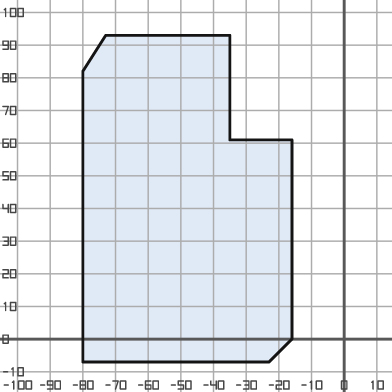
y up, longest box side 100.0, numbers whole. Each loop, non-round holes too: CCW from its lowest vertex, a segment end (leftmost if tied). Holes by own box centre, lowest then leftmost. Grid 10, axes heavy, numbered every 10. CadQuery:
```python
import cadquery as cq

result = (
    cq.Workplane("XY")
    .moveTo(-80.0, -7.0)
    .lineTo(-23.0, -7.0)
    .lineTo(-16.0, 0.0)
    .lineTo(-16.0, 61.0)
    .lineTo(-35.0, 61.0)
    .lineTo(-35.0, 93.0)
    .lineTo(-73.0, 93.0)
    .lineTo(-80.0, 82.0)
    .close()
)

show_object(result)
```